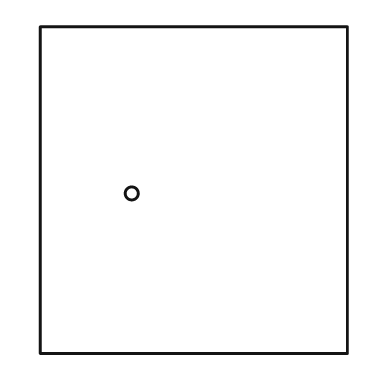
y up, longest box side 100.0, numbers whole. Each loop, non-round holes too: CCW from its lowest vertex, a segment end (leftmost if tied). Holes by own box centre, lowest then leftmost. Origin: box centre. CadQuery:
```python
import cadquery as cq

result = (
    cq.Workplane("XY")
    .moveTo(-47.0, -50.0)
    .lineTo(47.0, -50.0)
    .lineTo(47.0, 50.0)
    .lineTo(-47.0, 50.0)
    .close()
    .moveTo(-19.0, -1.0)
    .circle(2.0)
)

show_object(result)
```